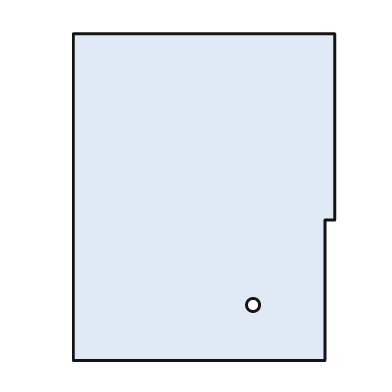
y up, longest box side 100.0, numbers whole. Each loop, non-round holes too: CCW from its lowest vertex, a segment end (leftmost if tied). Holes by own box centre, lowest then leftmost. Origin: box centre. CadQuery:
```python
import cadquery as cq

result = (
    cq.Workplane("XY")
    .moveTo(-40.0, -50.0)
    .lineTo(37.0, -50.0)
    .lineTo(37.0, -7.0)
    .lineTo(40.0, -7.0)
    .lineTo(40.0, 50.0)
    .lineTo(-40.0, 50.0)
    .close()
    .moveTo(15.0, -33.0)
    .circle(2.0)
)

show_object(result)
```